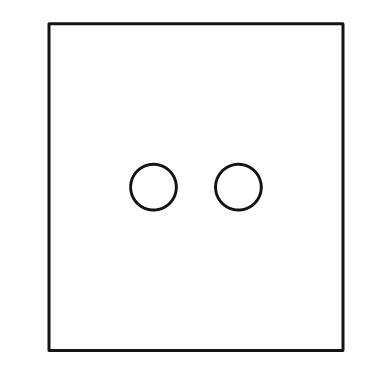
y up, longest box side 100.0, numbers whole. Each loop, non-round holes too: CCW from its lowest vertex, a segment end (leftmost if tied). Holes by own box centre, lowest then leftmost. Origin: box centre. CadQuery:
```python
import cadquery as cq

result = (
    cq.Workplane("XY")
    .moveTo(-45.0, -50.0)
    .lineTo(45.0, -50.0)
    .lineTo(45.0, 50.0)
    .lineTo(-45.0, 50.0)
    .close()
    .moveTo(-13.0, 0.0)
    .circle(7.0)
    .moveTo(13.0, 0.0)
    .circle(7.0)
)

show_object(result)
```